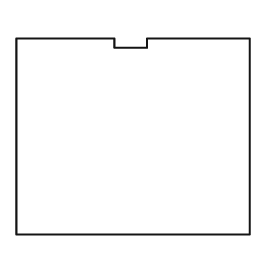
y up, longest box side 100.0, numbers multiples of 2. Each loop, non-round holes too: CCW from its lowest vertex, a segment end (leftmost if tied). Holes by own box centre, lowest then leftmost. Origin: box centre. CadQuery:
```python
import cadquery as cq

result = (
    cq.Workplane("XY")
    .moveTo(-50.0, -42.0)
    .lineTo(50.0, -42.0)
    .lineTo(50.0, 42.0)
    .lineTo(6.0, 42.0)
    .lineTo(6.0, 38.0)
    .lineTo(-8.0, 38.0)
    .lineTo(-8.0, 42.0)
    .lineTo(-50.0, 42.0)
    .close()
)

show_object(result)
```